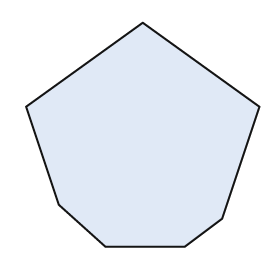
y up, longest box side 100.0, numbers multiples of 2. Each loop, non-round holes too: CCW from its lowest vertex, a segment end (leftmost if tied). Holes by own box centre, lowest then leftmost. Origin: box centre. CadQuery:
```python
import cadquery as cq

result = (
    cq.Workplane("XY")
    .moveTo(-16.0, -48.0)
    .lineTo(18.0, -48.0)
    .lineTo(34.0, -36.0)
    .lineTo(50.0, 12.0)
    .lineTo(0.0, 48.0)
    .lineTo(-50.0, 12.0)
    .lineTo(-36.0, -30.0)
    .close()
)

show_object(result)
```